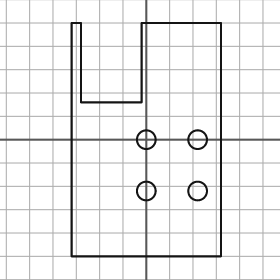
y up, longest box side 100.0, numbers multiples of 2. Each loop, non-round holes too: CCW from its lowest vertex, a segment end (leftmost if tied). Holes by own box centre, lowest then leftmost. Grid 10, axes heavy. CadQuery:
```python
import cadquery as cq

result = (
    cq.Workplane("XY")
    .moveTo(-32.0, -50.0)
    .lineTo(32.0, -50.0)
    .lineTo(32.0, 50.0)
    .lineTo(-2.0, 50.0)
    .lineTo(-2.0, 16.0)
    .lineTo(-28.0, 16.0)
    .lineTo(-28.0, 50.0)
    .lineTo(-32.0, 50.0)
    .close()
    .moveTo(0.0, -22.0)
    .circle(4.0)
    .moveTo(22.0, -22.0)
    .circle(4.0)
    .moveTo(0.0, 0.0)
    .circle(4.0)
    .moveTo(22.0, 0.0)
    .circle(4.0)
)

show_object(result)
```